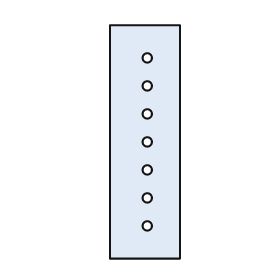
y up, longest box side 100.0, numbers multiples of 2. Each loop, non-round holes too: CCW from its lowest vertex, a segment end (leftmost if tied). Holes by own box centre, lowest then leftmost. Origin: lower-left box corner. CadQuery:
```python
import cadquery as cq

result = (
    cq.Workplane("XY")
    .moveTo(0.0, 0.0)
    .lineTo(30.0, 0.0)
    .lineTo(30.0, 100.0)
    .lineTo(0.0, 100.0)
    .close()
    .moveTo(16.0, 14.0)
    .circle(2.0)
    .moveTo(16.0, 26.0)
    .circle(2.0)
    .moveTo(16.0, 38.0)
    .circle(2.0)
    .moveTo(16.0, 50.0)
    .circle(2.0)
    .moveTo(16.0, 62.0)
    .circle(2.0)
    .moveTo(16.0, 74.0)
    .circle(2.0)
    .moveTo(16.0, 86.0)
    .circle(2.0)
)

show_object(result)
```